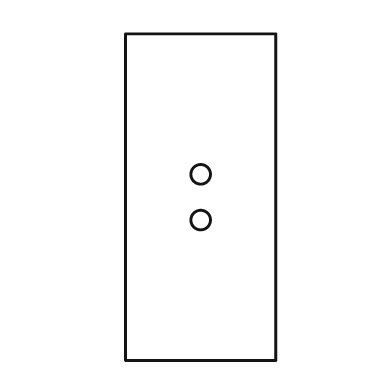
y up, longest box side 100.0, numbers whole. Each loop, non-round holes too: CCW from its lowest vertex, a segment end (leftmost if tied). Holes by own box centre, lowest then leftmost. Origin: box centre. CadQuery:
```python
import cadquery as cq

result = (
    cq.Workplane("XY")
    .moveTo(-23.0, -50.0)
    .lineTo(23.0, -50.0)
    .lineTo(23.0, 50.0)
    .lineTo(-23.0, 50.0)
    .close()
    .moveTo(0.0, -7.0)
    .circle(3.0)
    .moveTo(0.0, 7.0)
    .circle(3.0)
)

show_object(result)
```